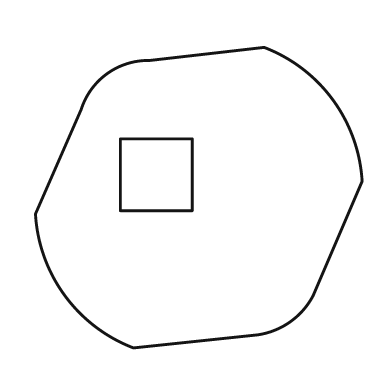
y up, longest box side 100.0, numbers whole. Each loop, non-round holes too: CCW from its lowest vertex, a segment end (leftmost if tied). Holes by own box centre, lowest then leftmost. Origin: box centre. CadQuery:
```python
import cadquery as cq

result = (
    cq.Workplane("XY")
    .moveTo(-20.0, -46.0)
    .lineTo(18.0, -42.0)
    .threePointArc((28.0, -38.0), (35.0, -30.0))
    .lineTo(50.0, 5.0)
    .threePointArc((41.0, 30.0), (20.0, 46.0))
    .lineTo(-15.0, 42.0)
    .threePointArc((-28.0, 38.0), (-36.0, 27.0))
    .lineTo(-50.0, -5.0)
    .threePointArc((-41.0, -30.0), (-20.0, -46.0))
    .close()
    .moveTo(-24.0, -4.0)
    .lineTo(-2.0, -4.0)
    .lineTo(-2.0, 18.0)
    .lineTo(-24.0, 18.0)
    .close()
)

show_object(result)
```